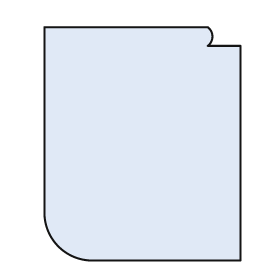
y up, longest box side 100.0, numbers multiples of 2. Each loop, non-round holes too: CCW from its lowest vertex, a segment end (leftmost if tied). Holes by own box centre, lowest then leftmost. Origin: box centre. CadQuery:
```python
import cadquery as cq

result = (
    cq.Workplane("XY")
    .moveTo(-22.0, -50.0)
    .lineTo(42.0, -50.0)
    .lineTo(42.0, 42.0)
    .lineTo(28.0, 42.0)
    .threePointArc((30.0, 46.0), (28.0, 50.0))
    .lineTo(-42.0, 50.0)
    .lineTo(-42.0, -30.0)
    .threePointArc((-36.0, -44.0), (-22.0, -50.0))
    .close()
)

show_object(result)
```